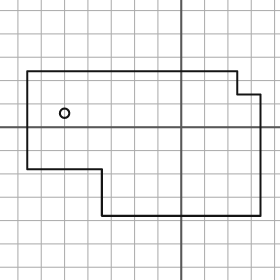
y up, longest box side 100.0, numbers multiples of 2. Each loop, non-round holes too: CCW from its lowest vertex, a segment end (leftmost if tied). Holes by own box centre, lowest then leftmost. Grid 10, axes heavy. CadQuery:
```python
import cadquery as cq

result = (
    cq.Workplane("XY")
    .moveTo(-34.0, -38.0)
    .lineTo(34.0, -38.0)
    .lineTo(34.0, 14.0)
    .lineTo(24.0, 14.0)
    .lineTo(24.0, 24.0)
    .lineTo(-66.0, 24.0)
    .lineTo(-66.0, -18.0)
    .lineTo(-34.0, -18.0)
    .close()
    .moveTo(-50.0, 6.0)
    .circle(2.0)
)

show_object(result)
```